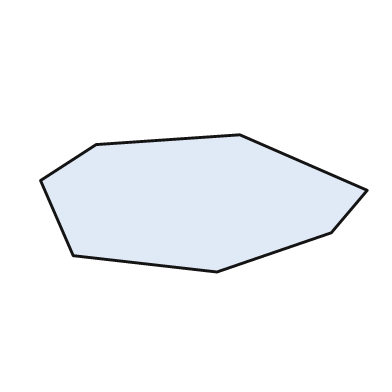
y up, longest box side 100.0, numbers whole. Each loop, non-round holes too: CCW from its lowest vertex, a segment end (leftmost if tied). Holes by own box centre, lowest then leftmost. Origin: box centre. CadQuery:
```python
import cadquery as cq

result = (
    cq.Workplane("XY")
    .moveTo(4.0, -21.0)
    .lineTo(39.0, -9.0)
    .lineTo(50.0, 4.0)
    .lineTo(11.0, 21.0)
    .lineTo(-33.0, 18.0)
    .lineTo(-50.0, 7.0)
    .lineTo(-40.0, -16.0)
    .close()
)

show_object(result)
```